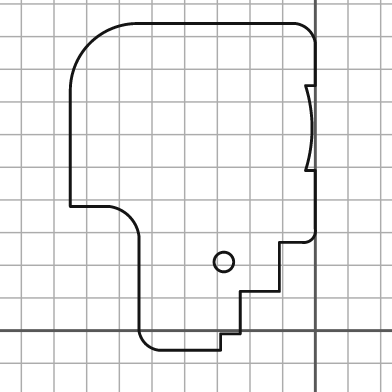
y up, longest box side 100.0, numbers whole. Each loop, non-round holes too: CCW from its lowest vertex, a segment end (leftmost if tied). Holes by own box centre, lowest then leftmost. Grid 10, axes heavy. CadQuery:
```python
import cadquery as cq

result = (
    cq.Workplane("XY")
    .moveTo(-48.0, -6.0)
    .lineTo(-29.0, -6.0)
    .lineTo(-29.0, -1.0)
    .lineTo(-23.0, -1.0)
    .lineTo(-23.0, 12.0)
    .lineTo(-11.0, 12.0)
    .lineTo(-11.0, 27.0)
    .lineTo(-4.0, 27.0)
    .threePointArc((-1.0, 28.0), (0.0, 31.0))
    .lineTo(0.0, 49.0)
    .lineTo(-3.0, 49.0)
    .threePointArc((-1.0, 62.0), (-3.0, 75.0))
    .lineTo(0.0, 75.0)
    .lineTo(0.0, 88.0)
    .threePointArc((-2.0, 92.0), (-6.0, 94.0))
    .lineTo(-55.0, 94.0)
    .threePointArc((-69.0, 88.0), (-75.0, 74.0))
    .lineTo(-75.0, 38.0)
    .lineTo(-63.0, 38.0)
    .threePointArc((-57.0, 35.0), (-54.0, 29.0))
    .lineTo(-54.0, 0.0)
    .threePointArc((-52.0, -4.0), (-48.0, -6.0))
    .close()
    .moveTo(-28.0, 21.0)
    .circle(3.0)
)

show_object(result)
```